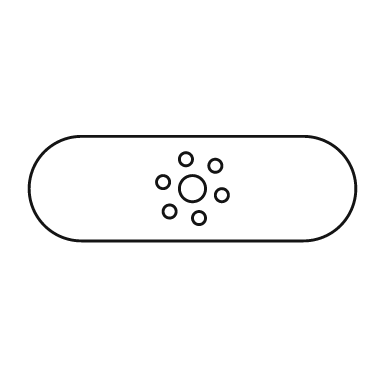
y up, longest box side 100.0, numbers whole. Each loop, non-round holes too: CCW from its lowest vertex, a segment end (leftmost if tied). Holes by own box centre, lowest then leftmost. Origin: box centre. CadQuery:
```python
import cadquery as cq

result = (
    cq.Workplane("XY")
    .moveTo(-34.0, -16.0)
    .lineTo(34.0, -16.0)
    .threePointArc((50.0, 0.0), (34.0, 16.0))
    .lineTo(-34.0, 16.0)
    .threePointArc((-50.0, 0.0), (-34.0, -16.0))
    .close()
    .moveTo(2.0, -9.0)
    .circle(2.0)
    .moveTo(-7.0, -7.0)
    .circle(2.0)
    .moveTo(9.0, -2.0)
    .circle(2.0)
    .moveTo(0.0, 0.0)
    .circle(4.0)
    .moveTo(-9.0, 2.0)
    .circle(2.0)
    .moveTo(7.0, 7.0)
    .circle(2.0)
    .moveTo(-2.0, 9.0)
    .circle(2.0)
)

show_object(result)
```